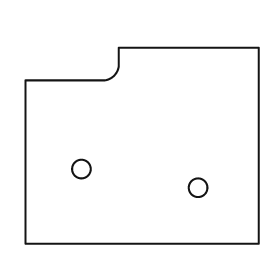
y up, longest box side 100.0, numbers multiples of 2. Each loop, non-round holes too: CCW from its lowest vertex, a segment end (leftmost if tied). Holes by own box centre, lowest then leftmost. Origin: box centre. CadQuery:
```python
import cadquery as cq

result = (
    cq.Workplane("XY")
    .moveTo(-50.0, -42.0)
    .lineTo(50.0, -42.0)
    .lineTo(50.0, 42.0)
    .lineTo(-10.0, 42.0)
    .lineTo(-10.0, 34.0)
    .threePointArc((-12.0, 30.0), (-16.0, 28.0))
    .lineTo(-50.0, 28.0)
    .close()
    .moveTo(24.0, -18.0)
    .circle(4.0)
    .moveTo(-26.0, -10.0)
    .circle(4.0)
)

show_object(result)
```